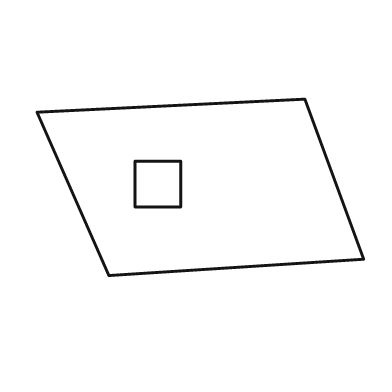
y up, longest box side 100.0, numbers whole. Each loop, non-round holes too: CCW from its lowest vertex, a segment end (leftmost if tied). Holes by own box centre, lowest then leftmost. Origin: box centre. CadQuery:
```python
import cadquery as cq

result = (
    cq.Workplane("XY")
    .moveTo(-28.0, -27.0)
    .lineTo(50.0, -22.0)
    .lineTo(32.0, 27.0)
    .lineTo(-50.0, 23.0)
    .close()
    .moveTo(-20.0, -6.0)
    .lineTo(-6.0, -6.0)
    .lineTo(-6.0, 8.0)
    .lineTo(-20.0, 8.0)
    .close()
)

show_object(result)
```